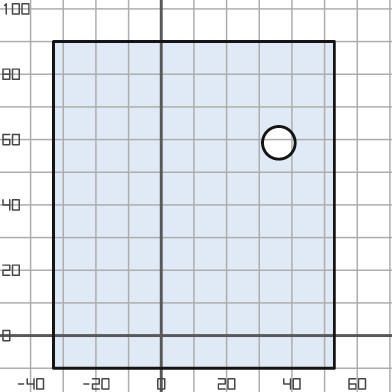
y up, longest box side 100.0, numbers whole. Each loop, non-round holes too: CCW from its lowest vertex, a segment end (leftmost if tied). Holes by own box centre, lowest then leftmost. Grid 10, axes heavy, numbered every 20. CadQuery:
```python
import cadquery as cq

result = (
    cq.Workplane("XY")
    .moveTo(-33.0, -10.0)
    .lineTo(53.0, -10.0)
    .lineTo(53.0, 90.0)
    .lineTo(-33.0, 90.0)
    .close()
    .moveTo(36.0, 59.0)
    .circle(5.0)
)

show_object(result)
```